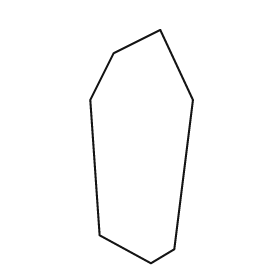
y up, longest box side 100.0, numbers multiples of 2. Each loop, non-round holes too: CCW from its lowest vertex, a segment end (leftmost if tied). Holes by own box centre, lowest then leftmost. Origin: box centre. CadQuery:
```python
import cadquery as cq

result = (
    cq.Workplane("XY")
    .moveTo(4.0, -50.0)
    .lineTo(14.0, -44.0)
    .lineTo(22.0, 20.0)
    .lineTo(8.0, 50.0)
    .lineTo(-12.0, 40.0)
    .lineTo(-22.0, 20.0)
    .lineTo(-18.0, -38.0)
    .close()
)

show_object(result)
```